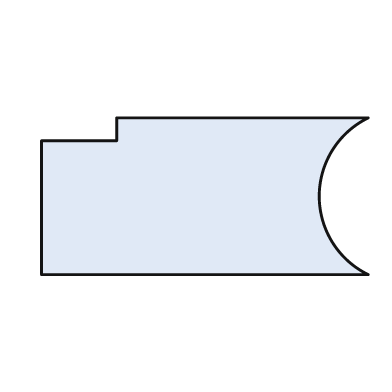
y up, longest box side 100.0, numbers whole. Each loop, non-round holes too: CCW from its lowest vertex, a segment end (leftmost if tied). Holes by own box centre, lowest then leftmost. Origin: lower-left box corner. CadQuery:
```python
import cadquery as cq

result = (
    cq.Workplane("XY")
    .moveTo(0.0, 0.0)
    .lineTo(100.0, 0.0)
    .threePointArc((85.0, 24.0), (100.0, 48.0))
    .lineTo(23.0, 48.0)
    .lineTo(23.0, 41.0)
    .lineTo(0.0, 41.0)
    .close()
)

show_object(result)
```